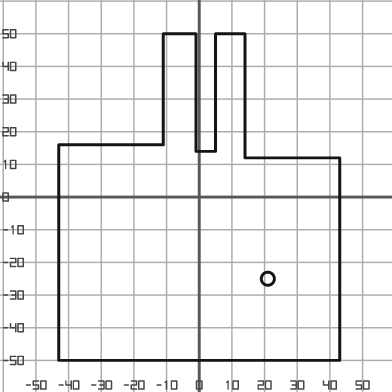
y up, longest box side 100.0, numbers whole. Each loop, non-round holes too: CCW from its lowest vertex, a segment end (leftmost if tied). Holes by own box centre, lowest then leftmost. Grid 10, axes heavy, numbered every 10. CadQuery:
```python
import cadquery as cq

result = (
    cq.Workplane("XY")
    .moveTo(-43.0, -50.0)
    .lineTo(43.0, -50.0)
    .lineTo(43.0, 12.0)
    .lineTo(14.0, 12.0)
    .lineTo(14.0, 50.0)
    .lineTo(5.0, 50.0)
    .lineTo(5.0, 14.0)
    .lineTo(-1.0, 14.0)
    .lineTo(-1.0, 50.0)
    .lineTo(-11.0, 50.0)
    .lineTo(-11.0, 16.0)
    .lineTo(-43.0, 16.0)
    .close()
    .moveTo(21.0, -25.0)
    .circle(2.0)
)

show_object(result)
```